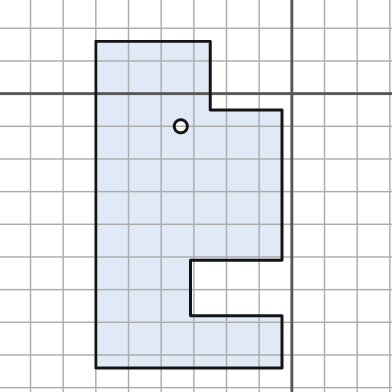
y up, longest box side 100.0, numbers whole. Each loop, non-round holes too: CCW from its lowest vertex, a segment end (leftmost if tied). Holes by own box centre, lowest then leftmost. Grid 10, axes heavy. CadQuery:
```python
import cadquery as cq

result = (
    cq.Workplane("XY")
    .moveTo(-60.0, -84.0)
    .lineTo(-3.0, -84.0)
    .lineTo(-3.0, -68.0)
    .lineTo(-31.0, -68.0)
    .lineTo(-31.0, -51.0)
    .lineTo(-3.0, -51.0)
    .lineTo(-3.0, -5.0)
    .lineTo(-25.0, -5.0)
    .lineTo(-25.0, 16.0)
    .lineTo(-60.0, 16.0)
    .close()
    .moveTo(-34.0, -10.0)
    .circle(2.0)
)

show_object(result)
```